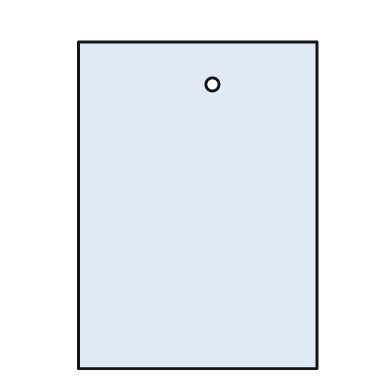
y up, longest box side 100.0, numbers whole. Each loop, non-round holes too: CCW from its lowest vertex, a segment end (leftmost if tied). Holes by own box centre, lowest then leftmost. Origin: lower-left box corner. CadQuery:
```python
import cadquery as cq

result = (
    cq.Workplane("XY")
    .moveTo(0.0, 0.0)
    .lineTo(73.0, 0.0)
    .lineTo(73.0, 100.0)
    .lineTo(0.0, 100.0)
    .close()
    .moveTo(41.0, 87.0)
    .circle(2.0)
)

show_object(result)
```